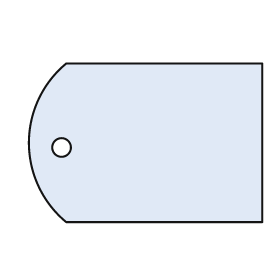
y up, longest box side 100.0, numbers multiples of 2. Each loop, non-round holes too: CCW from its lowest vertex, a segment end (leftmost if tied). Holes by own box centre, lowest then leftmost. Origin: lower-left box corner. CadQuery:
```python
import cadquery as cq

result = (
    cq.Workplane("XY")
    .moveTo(16.0, 0.0)
    .lineTo(100.0, 0.0)
    .lineTo(100.0, 68.0)
    .lineTo(16.0, 68.0)
    .threePointArc((0.0, 34.0), (16.0, 0.0))
    .close()
    .moveTo(14.0, 32.0)
    .circle(4.0)
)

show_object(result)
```